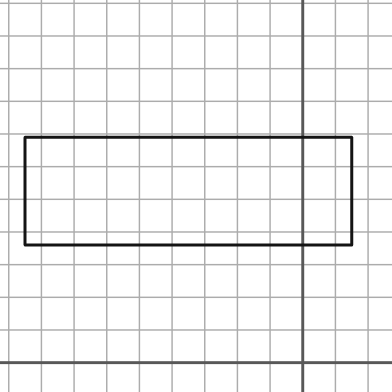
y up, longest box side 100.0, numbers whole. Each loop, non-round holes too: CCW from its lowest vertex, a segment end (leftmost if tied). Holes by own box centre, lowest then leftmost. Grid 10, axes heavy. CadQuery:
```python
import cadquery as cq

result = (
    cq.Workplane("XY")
    .moveTo(-85.0, 36.0)
    .lineTo(15.0, 36.0)
    .lineTo(15.0, 69.0)
    .lineTo(-85.0, 69.0)
    .close()
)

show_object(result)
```